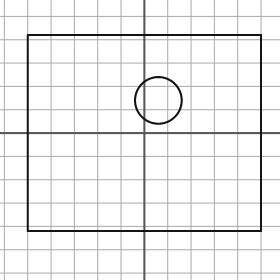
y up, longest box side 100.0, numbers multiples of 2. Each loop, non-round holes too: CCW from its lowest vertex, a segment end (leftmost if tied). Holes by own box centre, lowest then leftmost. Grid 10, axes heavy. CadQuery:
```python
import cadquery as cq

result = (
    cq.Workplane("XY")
    .moveTo(-50.0, -42.0)
    .lineTo(50.0, -42.0)
    .lineTo(50.0, 42.0)
    .lineTo(-50.0, 42.0)
    .close()
    .moveTo(6.0, 14.0)
    .circle(10.0)
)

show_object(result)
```